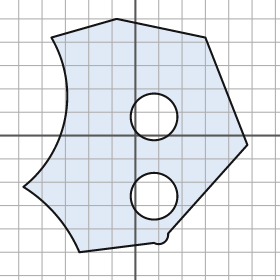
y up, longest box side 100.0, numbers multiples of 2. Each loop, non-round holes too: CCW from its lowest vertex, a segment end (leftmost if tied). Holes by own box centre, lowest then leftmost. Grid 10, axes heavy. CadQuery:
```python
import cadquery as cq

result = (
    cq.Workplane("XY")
    .moveTo(-24.0, -50.0)
    .lineTo(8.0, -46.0)
    .threePointArc((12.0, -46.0), (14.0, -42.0))
    .lineTo(48.0, -4.0)
    .lineTo(30.0, 42.0)
    .lineTo(-8.0, 50.0)
    .lineTo(-36.0, 42.0)
    .threePointArc((-30.0, 8.0), (-48.0, -22.0))
    .threePointArc((-34.0, -34.0), (-24.0, -50.0))
    .close()
    .moveTo(8.0, -26.0)
    .circle(10.0)
    .moveTo(8.0, 8.0)
    .circle(10.0)
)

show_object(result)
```